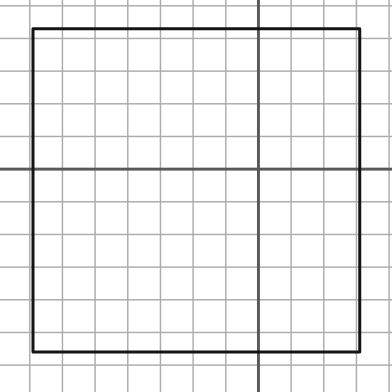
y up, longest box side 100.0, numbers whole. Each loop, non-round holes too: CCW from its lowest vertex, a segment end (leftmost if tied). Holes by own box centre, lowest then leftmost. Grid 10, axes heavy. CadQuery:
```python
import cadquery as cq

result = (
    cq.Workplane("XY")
    .moveTo(-69.0, -56.0)
    .lineTo(31.0, -56.0)
    .lineTo(31.0, 43.0)
    .lineTo(-69.0, 43.0)
    .close()
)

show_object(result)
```